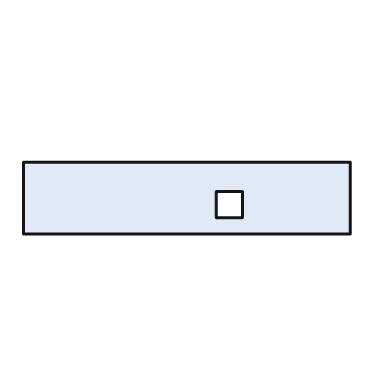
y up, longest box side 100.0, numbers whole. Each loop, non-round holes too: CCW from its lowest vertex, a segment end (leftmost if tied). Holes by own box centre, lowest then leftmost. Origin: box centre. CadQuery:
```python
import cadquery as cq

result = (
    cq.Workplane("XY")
    .moveTo(-50.0, -11.0)
    .lineTo(50.0, -11.0)
    .lineTo(50.0, 11.0)
    .lineTo(-50.0, 11.0)
    .close()
    .moveTo(9.0, -6.0)
    .lineTo(17.0, -6.0)
    .lineTo(17.0, 2.0)
    .lineTo(9.0, 2.0)
    .close()
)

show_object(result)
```